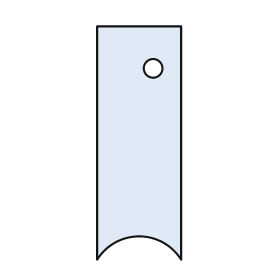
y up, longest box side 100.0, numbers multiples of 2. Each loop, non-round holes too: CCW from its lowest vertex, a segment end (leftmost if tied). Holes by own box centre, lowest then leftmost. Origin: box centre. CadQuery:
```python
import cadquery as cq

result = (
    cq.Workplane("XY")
    .moveTo(-18.0, -50.0)
    .threePointArc((0.0, -40.0), (18.0, -50.0))
    .lineTo(18.0, 50.0)
    .lineTo(-18.0, 50.0)
    .close()
    .moveTo(6.0, 32.0)
    .circle(4.0)
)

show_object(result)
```